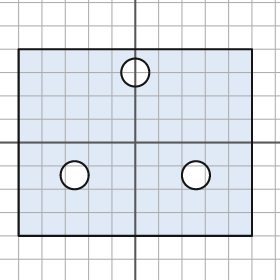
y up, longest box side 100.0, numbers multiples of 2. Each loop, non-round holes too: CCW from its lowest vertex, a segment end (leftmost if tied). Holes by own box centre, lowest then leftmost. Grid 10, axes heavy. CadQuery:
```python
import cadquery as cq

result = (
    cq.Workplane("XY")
    .moveTo(-50.0, -40.0)
    .lineTo(50.0, -40.0)
    .lineTo(50.0, 40.0)
    .lineTo(-50.0, 40.0)
    .close()
    .moveTo(-26.0, -14.0)
    .circle(6.0)
    .moveTo(26.0, -14.0)
    .circle(6.0)
    .moveTo(0.0, 30.0)
    .circle(6.0)
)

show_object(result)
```